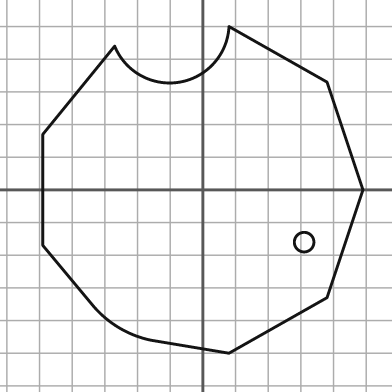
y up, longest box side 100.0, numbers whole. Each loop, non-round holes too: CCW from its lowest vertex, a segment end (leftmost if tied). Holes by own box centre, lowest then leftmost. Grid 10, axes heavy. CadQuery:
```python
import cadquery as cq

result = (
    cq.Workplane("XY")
    .moveTo(8.0, -50.0)
    .lineTo(38.0, -33.0)
    .lineTo(49.0, 0.0)
    .lineTo(38.0, 33.0)
    .lineTo(8.0, 50.0)
    .threePointArc((-7.0, 33.0), (-27.0, 44.0))
    .lineTo(-49.0, 17.0)
    .lineTo(-49.0, -17.0)
    .lineTo(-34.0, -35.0)
    .threePointArc((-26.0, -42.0), (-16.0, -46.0))
    .close()
    .moveTo(31.0, -16.0)
    .circle(3.0)
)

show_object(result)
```